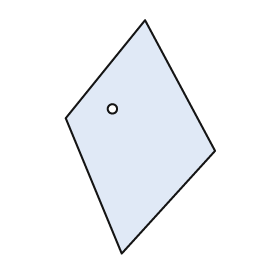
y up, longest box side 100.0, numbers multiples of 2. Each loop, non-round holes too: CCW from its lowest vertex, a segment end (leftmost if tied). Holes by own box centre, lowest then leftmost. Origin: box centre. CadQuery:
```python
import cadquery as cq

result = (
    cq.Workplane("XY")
    .moveTo(-8.0, -50.0)
    .lineTo(32.0, -6.0)
    .lineTo(2.0, 50.0)
    .lineTo(-32.0, 8.0)
    .close()
    .moveTo(-12.0, 12.0)
    .circle(2.0)
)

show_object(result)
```